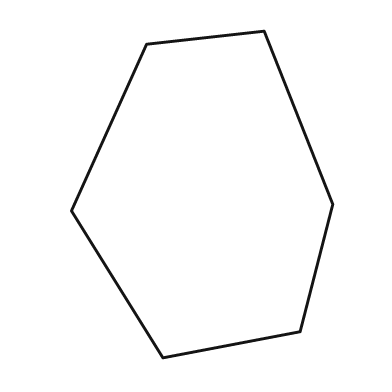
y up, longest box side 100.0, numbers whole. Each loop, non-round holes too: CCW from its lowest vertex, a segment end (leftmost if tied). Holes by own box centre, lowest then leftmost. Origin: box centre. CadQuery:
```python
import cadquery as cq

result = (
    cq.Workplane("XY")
    .moveTo(-12.0, -50.0)
    .lineTo(30.0, -42.0)
    .lineTo(40.0, -3.0)
    .lineTo(19.0, 50.0)
    .lineTo(-17.0, 46.0)
    .lineTo(-40.0, -5.0)
    .close()
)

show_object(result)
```